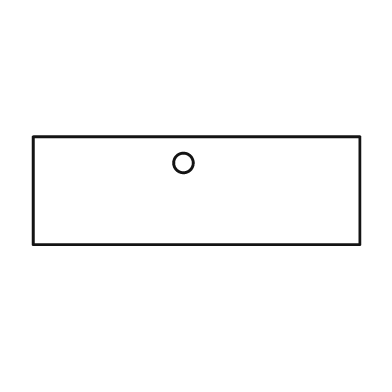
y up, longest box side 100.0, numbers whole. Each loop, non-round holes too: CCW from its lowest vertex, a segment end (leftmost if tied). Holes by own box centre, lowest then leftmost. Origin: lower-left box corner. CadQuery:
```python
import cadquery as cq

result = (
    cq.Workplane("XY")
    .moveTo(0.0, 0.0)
    .lineTo(100.0, 0.0)
    .lineTo(100.0, 33.0)
    .lineTo(0.0, 33.0)
    .close()
    .moveTo(46.0, 25.0)
    .circle(3.0)
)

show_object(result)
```